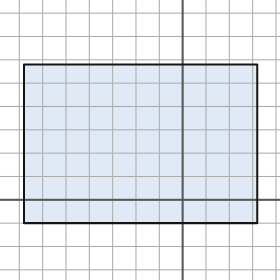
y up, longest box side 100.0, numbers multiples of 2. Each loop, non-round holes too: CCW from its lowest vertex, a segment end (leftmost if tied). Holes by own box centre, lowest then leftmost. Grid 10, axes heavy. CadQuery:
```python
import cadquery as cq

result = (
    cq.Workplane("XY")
    .moveTo(-68.0, -10.0)
    .lineTo(32.0, -10.0)
    .lineTo(32.0, 58.0)
    .lineTo(-68.0, 58.0)
    .close()
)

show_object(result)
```